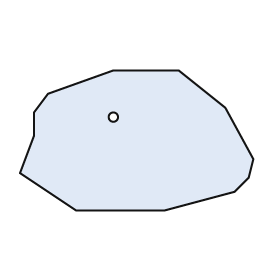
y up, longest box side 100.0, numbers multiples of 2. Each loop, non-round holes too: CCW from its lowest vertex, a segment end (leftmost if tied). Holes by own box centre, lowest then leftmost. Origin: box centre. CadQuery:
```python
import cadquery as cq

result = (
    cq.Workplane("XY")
    .moveTo(-26.0, -30.0)
    .lineTo(12.0, -30.0)
    .lineTo(42.0, -22.0)
    .lineTo(48.0, -16.0)
    .lineTo(50.0, -8.0)
    .lineTo(38.0, 14.0)
    .lineTo(18.0, 30.0)
    .lineTo(-10.0, 30.0)
    .lineTo(-38.0, 20.0)
    .lineTo(-44.0, 12.0)
    .lineTo(-44.0, 2.0)
    .lineTo(-50.0, -14.0)
    .close()
    .moveTo(-10.0, 10.0)
    .circle(2.0)
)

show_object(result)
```